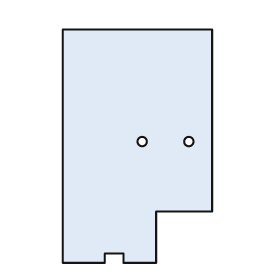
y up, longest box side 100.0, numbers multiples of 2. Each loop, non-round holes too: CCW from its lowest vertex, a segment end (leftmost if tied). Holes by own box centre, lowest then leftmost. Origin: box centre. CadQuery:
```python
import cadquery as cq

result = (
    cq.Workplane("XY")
    .moveTo(-32.0, -50.0)
    .lineTo(-14.0, -50.0)
    .lineTo(-14.0, -46.0)
    .lineTo(-6.0, -46.0)
    .lineTo(-6.0, -50.0)
    .lineTo(8.0, -50.0)
    .lineTo(8.0, -28.0)
    .lineTo(32.0, -28.0)
    .lineTo(32.0, 50.0)
    .lineTo(-32.0, 50.0)
    .close()
    .moveTo(2.0, 2.0)
    .circle(2.0)
    .moveTo(22.0, 2.0)
    .circle(2.0)
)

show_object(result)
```